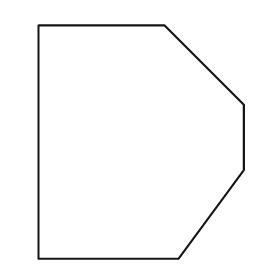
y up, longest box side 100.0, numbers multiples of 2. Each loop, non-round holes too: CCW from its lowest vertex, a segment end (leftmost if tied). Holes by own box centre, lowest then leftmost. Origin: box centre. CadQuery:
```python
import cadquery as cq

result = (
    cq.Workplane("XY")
    .moveTo(-44.0, -50.0)
    .lineTo(16.0, -50.0)
    .lineTo(44.0, -12.0)
    .lineTo(44.0, 16.0)
    .lineTo(10.0, 50.0)
    .lineTo(-44.0, 50.0)
    .close()
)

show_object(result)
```